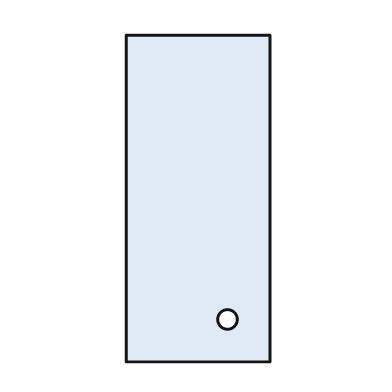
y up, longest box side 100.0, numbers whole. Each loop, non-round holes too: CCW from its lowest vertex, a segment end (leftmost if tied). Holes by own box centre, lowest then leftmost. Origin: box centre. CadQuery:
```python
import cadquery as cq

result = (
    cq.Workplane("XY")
    .moveTo(-22.0, -50.0)
    .lineTo(22.0, -50.0)
    .lineTo(22.0, 50.0)
    .lineTo(-22.0, 50.0)
    .close()
    .moveTo(9.0, -37.0)
    .circle(3.0)
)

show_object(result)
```